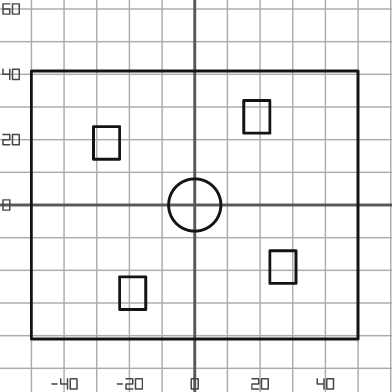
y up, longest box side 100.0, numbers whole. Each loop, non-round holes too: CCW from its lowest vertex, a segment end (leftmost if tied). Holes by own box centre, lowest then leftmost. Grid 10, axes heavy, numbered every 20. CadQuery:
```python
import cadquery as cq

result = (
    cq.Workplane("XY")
    .moveTo(-50.0, -41.0)
    .lineTo(50.0, -41.0)
    .lineTo(50.0, 41.0)
    .lineTo(-50.0, 41.0)
    .close()
    .moveTo(-23.0, -32.0)
    .lineTo(-15.0, -32.0)
    .lineTo(-15.0, -22.0)
    .lineTo(-23.0, -22.0)
    .close()
    .moveTo(23.0, -24.0)
    .lineTo(31.0, -24.0)
    .lineTo(31.0, -14.0)
    .lineTo(23.0, -14.0)
    .close()
    .moveTo(0.0, 0.0)
    .circle(8.0)
    .moveTo(-31.0, 14.0)
    .lineTo(-23.0, 14.0)
    .lineTo(-23.0, 24.0)
    .lineTo(-31.0, 24.0)
    .close()
    .moveTo(15.0, 22.0)
    .lineTo(23.0, 22.0)
    .lineTo(23.0, 32.0)
    .lineTo(15.0, 32.0)
    .close()
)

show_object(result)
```